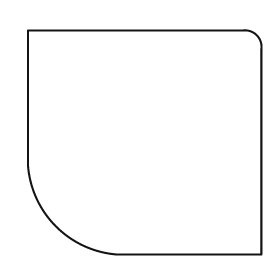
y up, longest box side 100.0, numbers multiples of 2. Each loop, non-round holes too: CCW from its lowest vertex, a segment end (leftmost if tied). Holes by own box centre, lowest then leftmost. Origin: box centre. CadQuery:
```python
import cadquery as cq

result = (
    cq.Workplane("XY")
    .moveTo(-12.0, -48.0)
    .lineTo(50.0, -48.0)
    .lineTo(50.0, 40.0)
    .threePointArc((48.0, 46.0), (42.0, 48.0))
    .lineTo(-50.0, 48.0)
    .lineTo(-50.0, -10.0)
    .threePointArc((-38.0, -36.0), (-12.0, -48.0))
    .close()
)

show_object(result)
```